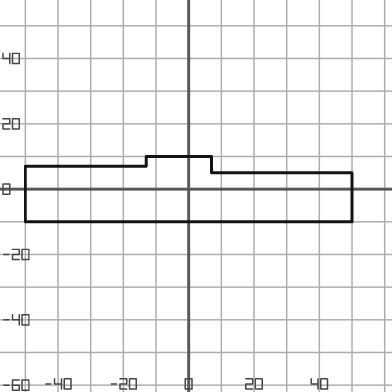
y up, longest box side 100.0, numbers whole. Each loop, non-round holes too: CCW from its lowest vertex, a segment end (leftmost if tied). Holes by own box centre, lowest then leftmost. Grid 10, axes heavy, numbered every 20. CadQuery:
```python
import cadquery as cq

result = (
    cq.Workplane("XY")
    .moveTo(-50.0, -10.0)
    .lineTo(50.0, -10.0)
    .lineTo(50.0, 5.0)
    .lineTo(7.0, 5.0)
    .lineTo(7.0, 10.0)
    .lineTo(-13.0, 10.0)
    .lineTo(-13.0, 7.0)
    .lineTo(-50.0, 7.0)
    .close()
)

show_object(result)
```